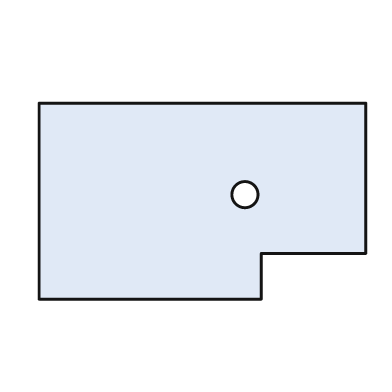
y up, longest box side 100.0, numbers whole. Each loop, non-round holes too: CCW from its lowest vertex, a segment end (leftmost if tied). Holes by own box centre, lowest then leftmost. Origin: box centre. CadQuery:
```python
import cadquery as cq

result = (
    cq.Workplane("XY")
    .moveTo(-50.0, -30.0)
    .lineTo(18.0, -30.0)
    .lineTo(18.0, -16.0)
    .lineTo(50.0, -16.0)
    .lineTo(50.0, 30.0)
    .lineTo(-50.0, 30.0)
    .close()
    .moveTo(13.0, 2.0)
    .circle(4.0)
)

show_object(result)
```